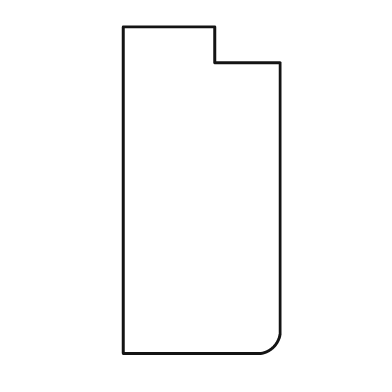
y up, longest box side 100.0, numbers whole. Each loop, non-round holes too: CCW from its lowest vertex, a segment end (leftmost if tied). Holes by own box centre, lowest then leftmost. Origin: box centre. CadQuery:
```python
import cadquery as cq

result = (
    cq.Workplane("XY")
    .moveTo(-24.0, -50.0)
    .lineTo(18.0, -50.0)
    .threePointArc((22.0, -48.0), (24.0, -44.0))
    .lineTo(24.0, 39.0)
    .lineTo(4.0, 39.0)
    .lineTo(4.0, 50.0)
    .lineTo(-24.0, 50.0)
    .close()
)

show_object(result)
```